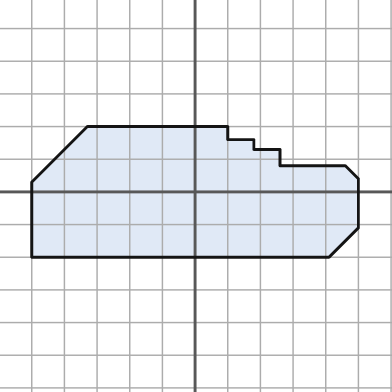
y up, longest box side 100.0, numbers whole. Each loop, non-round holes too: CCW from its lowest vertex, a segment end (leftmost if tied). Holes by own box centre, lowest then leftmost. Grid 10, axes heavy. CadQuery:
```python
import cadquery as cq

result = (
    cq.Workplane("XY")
    .moveTo(-50.0, -20.0)
    .lineTo(41.0, -20.0)
    .lineTo(50.0, -11.0)
    .lineTo(50.0, 4.0)
    .lineTo(46.0, 8.0)
    .lineTo(26.0, 8.0)
    .lineTo(26.0, 13.0)
    .lineTo(18.0, 13.0)
    .lineTo(18.0, 16.0)
    .lineTo(10.0, 16.0)
    .lineTo(10.0, 20.0)
    .lineTo(-33.0, 20.0)
    .lineTo(-50.0, 3.0)
    .close()
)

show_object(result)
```